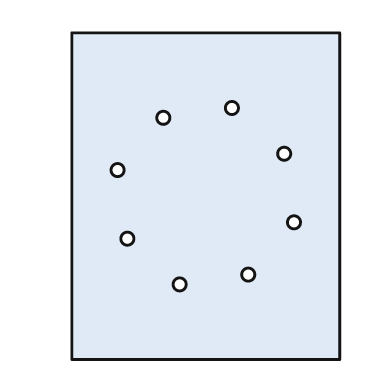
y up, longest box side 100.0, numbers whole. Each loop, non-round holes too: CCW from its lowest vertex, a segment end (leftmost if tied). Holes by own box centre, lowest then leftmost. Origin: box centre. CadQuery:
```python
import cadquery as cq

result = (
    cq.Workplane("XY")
    .moveTo(-41.0, -50.0)
    .lineTo(41.0, -50.0)
    .lineTo(41.0, 50.0)
    .lineTo(-41.0, 50.0)
    .close()
    .moveTo(-8.0, -27.0)
    .circle(2.0)
    .moveTo(13.0, -24.0)
    .circle(2.0)
    .moveTo(-24.0, -13.0)
    .circle(2.0)
    .moveTo(27.0, -8.0)
    .circle(2.0)
    .moveTo(-27.0, 8.0)
    .circle(2.0)
    .moveTo(24.0, 13.0)
    .circle(2.0)
    .moveTo(-13.0, 24.0)
    .circle(2.0)
    .moveTo(8.0, 27.0)
    .circle(2.0)
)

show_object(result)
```